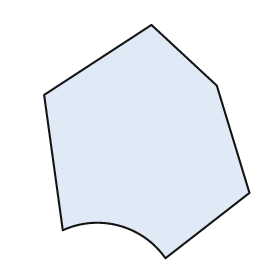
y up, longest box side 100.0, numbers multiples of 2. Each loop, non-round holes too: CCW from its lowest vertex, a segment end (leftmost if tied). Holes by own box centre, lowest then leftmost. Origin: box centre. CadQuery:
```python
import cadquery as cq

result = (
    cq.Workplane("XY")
    .moveTo(8.0, -50.0)
    .lineTo(44.0, -22.0)
    .lineTo(30.0, 24.0)
    .lineTo(2.0, 50.0)
    .lineTo(-44.0, 20.0)
    .lineTo(-36.0, -38.0)
    .threePointArc((-12.0, -36.0), (8.0, -50.0))
    .close()
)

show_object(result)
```